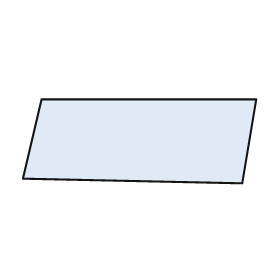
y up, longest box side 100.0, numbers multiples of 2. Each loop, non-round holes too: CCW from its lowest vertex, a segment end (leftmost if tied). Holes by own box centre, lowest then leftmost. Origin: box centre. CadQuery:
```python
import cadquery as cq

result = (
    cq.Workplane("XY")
    .moveTo(44.0, -18.0)
    .lineTo(50.0, 18.0)
    .lineTo(-42.0, 18.0)
    .lineTo(-50.0, -16.0)
    .close()
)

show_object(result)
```